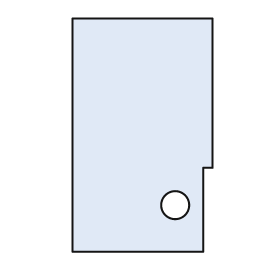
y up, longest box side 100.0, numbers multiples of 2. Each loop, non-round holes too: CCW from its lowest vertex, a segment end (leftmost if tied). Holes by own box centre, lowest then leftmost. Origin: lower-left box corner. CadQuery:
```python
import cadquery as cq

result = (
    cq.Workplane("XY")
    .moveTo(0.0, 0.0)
    .lineTo(56.0, 0.0)
    .lineTo(56.0, 36.0)
    .lineTo(60.0, 36.0)
    .lineTo(60.0, 100.0)
    .lineTo(0.0, 100.0)
    .close()
    .moveTo(44.0, 20.0)
    .circle(6.0)
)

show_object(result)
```